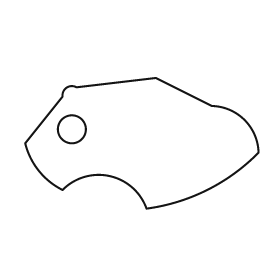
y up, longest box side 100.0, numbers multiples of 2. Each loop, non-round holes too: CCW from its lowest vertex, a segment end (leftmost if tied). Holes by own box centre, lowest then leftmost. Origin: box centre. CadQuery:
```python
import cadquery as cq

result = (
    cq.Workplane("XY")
    .moveTo(2.0, -28.0)
    .threePointArc((28.0, -20.0), (50.0, -4.0))
    .threePointArc((44.0, 10.0), (30.0, 16.0))
    .lineTo(6.0, 28.0)
    .lineTo(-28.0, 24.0)
    .threePointArc((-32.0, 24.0), (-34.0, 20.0))
    .lineTo(-50.0, 0.0)
    .threePointArc((-44.0, -12.0), (-34.0, -20.0))
    .threePointArc((-14.0, -14.0), (2.0, -28.0))
    .close()
    .moveTo(-30.0, 6.0)
    .circle(6.0)
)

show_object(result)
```